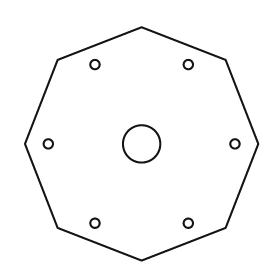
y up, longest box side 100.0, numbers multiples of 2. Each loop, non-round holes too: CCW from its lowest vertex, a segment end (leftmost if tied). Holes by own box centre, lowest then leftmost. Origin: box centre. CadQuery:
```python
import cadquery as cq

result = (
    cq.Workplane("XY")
    .moveTo(0.0, -50.0)
    .lineTo(36.0, -36.0)
    .lineTo(50.0, 0.0)
    .lineTo(36.0, 36.0)
    .lineTo(0.0, 50.0)
    .lineTo(-36.0, 36.0)
    .lineTo(-50.0, 0.0)
    .lineTo(-36.0, -36.0)
    .close()
    .moveTo(-20.0, -34.0)
    .circle(2.0)
    .moveTo(20.0, -34.0)
    .circle(2.0)
    .moveTo(-40.0, 0.0)
    .circle(2.0)
    .moveTo(0.0, 0.0)
    .circle(8.0)
    .moveTo(40.0, 0.0)
    .circle(2.0)
    .moveTo(-20.0, 34.0)
    .circle(2.0)
    .moveTo(20.0, 34.0)
    .circle(2.0)
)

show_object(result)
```